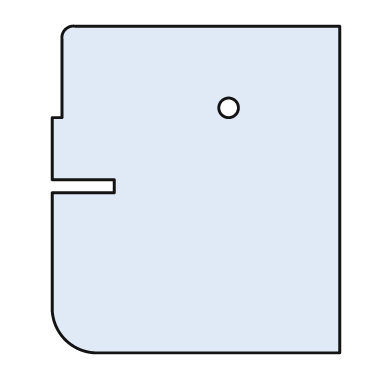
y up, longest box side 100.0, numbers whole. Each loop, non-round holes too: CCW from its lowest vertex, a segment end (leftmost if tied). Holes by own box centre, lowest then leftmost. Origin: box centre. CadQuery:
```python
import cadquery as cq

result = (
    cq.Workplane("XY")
    .moveTo(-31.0, -50.0)
    .lineTo(44.0, -50.0)
    .lineTo(44.0, 50.0)
    .lineTo(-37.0, 50.0)
    .threePointArc((-40.0, 49.0), (-41.0, 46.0))
    .lineTo(-41.0, 22.0)
    .lineTo(-44.0, 22.0)
    .lineTo(-44.0, 3.0)
    .lineTo(-25.0, 3.0)
    .lineTo(-25.0, -1.0)
    .lineTo(-44.0, -1.0)
    .lineTo(-44.0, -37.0)
    .threePointArc((-40.0, -46.0), (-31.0, -50.0))
    .close()
    .moveTo(10.0, 25.0)
    .circle(3.0)
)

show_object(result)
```